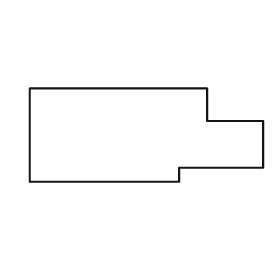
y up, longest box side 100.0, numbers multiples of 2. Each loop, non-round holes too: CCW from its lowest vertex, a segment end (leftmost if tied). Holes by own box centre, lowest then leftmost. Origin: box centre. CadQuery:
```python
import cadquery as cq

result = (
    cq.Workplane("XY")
    .moveTo(-50.0, -20.0)
    .lineTo(14.0, -20.0)
    .lineTo(14.0, -14.0)
    .lineTo(50.0, -14.0)
    .lineTo(50.0, 6.0)
    .lineTo(26.0, 6.0)
    .lineTo(26.0, 20.0)
    .lineTo(-50.0, 20.0)
    .close()
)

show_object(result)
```